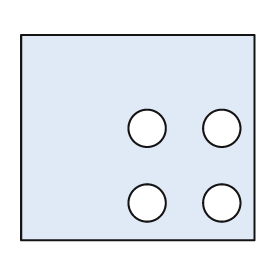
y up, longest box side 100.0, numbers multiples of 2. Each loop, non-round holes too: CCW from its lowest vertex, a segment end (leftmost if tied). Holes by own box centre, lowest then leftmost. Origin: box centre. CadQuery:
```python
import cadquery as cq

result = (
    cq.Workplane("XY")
    .moveTo(-50.0, -44.0)
    .lineTo(50.0, -44.0)
    .lineTo(50.0, 44.0)
    .lineTo(-50.0, 44.0)
    .close()
    .moveTo(4.0, -28.0)
    .circle(8.0)
    .moveTo(36.0, -28.0)
    .circle(8.0)
    .moveTo(4.0, 4.0)
    .circle(8.0)
    .moveTo(36.0, 4.0)
    .circle(8.0)
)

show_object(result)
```